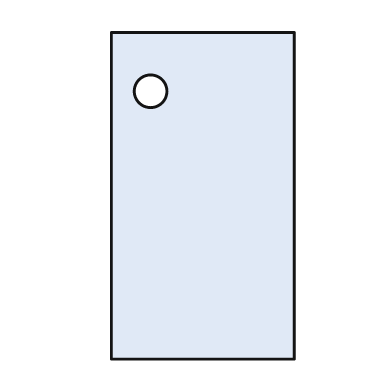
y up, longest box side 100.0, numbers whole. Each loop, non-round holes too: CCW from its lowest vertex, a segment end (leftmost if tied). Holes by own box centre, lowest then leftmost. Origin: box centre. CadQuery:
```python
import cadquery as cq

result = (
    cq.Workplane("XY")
    .moveTo(-28.0, -50.0)
    .lineTo(28.0, -50.0)
    .lineTo(28.0, 50.0)
    .lineTo(-28.0, 50.0)
    .close()
    .moveTo(-16.0, 32.0)
    .circle(5.0)
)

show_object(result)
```